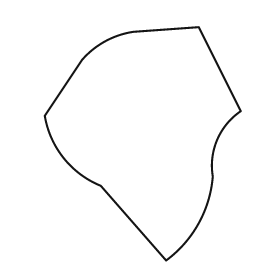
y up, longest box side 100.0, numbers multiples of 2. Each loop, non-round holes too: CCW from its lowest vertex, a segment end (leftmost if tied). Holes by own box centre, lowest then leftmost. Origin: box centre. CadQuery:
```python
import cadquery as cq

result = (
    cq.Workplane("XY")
    .moveTo(10.0, -50.0)
    .threePointArc((24.0, -34.0), (30.0, -14.0))
    .threePointArc((32.0, 2.0), (42.0, 14.0))
    .lineTo(24.0, 50.0)
    .lineTo(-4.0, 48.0)
    .threePointArc((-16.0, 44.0), (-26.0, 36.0))
    .lineTo(-42.0, 12.0)
    .threePointArc((-34.0, -6.0), (-18.0, -18.0))
    .close()
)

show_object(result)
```